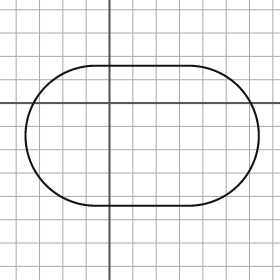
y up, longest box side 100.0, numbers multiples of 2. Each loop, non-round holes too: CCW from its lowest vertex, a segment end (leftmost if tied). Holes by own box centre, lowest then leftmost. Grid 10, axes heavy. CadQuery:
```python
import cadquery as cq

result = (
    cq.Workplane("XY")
    .moveTo(-6.0, -44.0)
    .lineTo(34.0, -44.0)
    .threePointArc((64.0, -14.0), (34.0, 16.0))
    .lineTo(-6.0, 16.0)
    .threePointArc((-36.0, -14.0), (-6.0, -44.0))
    .close()
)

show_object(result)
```